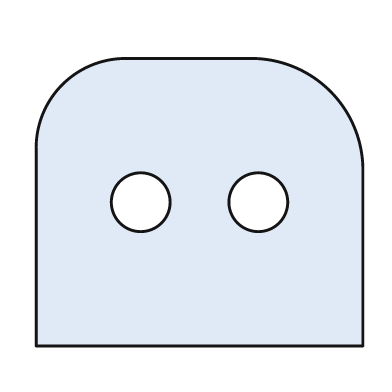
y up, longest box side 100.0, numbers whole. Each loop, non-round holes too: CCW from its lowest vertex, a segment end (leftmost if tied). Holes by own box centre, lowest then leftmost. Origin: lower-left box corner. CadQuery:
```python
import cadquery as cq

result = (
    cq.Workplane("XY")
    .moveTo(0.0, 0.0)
    .lineTo(100.0, 0.0)
    .lineTo(100.0, 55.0)
    .threePointArc((90.0, 78.0), (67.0, 88.0))
    .lineTo(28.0, 88.0)
    .threePointArc((8.0, 80.0), (0.0, 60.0))
    .close()
    .moveTo(32.0, 44.0)
    .circle(9.0)
    .moveTo(68.0, 44.0)
    .circle(9.0)
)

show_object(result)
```